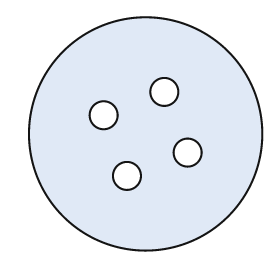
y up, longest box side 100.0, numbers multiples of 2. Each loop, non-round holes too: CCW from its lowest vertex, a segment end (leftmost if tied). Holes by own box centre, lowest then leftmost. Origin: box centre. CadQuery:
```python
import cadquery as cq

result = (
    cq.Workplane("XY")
    .moveTo(0.0, 0.0)
    .circle(50.0)
    .moveTo(-8.0, -18.0)
    .circle(6.0)
    .moveTo(18.0, -8.0)
    .circle(6.0)
    .moveTo(-18.0, 8.0)
    .circle(6.0)
    .moveTo(8.0, 18.0)
    .circle(6.0)
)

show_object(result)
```